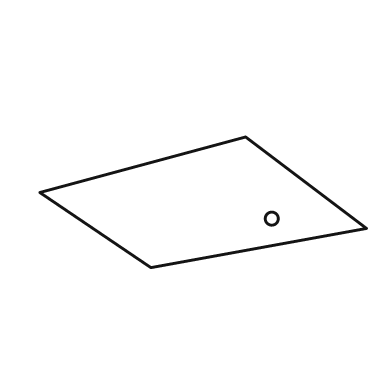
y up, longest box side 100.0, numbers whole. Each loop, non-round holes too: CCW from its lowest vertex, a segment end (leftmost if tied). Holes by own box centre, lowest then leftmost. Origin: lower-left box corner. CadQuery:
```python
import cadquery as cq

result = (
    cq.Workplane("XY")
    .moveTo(34.0, 0.0)
    .lineTo(100.0, 12.0)
    .lineTo(63.0, 40.0)
    .lineTo(0.0, 23.0)
    .close()
    .moveTo(71.0, 15.0)
    .circle(2.0)
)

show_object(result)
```